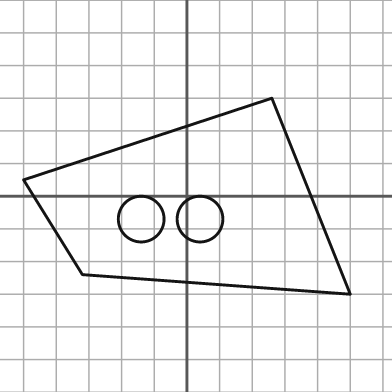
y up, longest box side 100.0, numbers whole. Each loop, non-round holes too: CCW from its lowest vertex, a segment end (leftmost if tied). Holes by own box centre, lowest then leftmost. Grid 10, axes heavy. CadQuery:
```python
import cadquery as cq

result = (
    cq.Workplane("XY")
    .moveTo(50.0, -30.0)
    .lineTo(26.0, 30.0)
    .lineTo(-50.0, 5.0)
    .lineTo(-32.0, -24.0)
    .close()
    .moveTo(-14.0, -7.0)
    .circle(7.0)
    .moveTo(4.0, -7.0)
    .circle(7.0)
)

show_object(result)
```